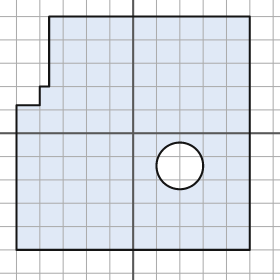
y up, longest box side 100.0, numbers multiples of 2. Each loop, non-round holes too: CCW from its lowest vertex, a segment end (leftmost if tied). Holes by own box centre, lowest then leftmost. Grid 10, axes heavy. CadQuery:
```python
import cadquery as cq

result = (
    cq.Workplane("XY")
    .moveTo(-50.0, -50.0)
    .lineTo(50.0, -50.0)
    .lineTo(50.0, 50.0)
    .lineTo(-36.0, 50.0)
    .lineTo(-36.0, 20.0)
    .lineTo(-40.0, 20.0)
    .lineTo(-40.0, 12.0)
    .lineTo(-50.0, 12.0)
    .close()
    .moveTo(20.0, -14.0)
    .circle(10.0)
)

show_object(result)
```